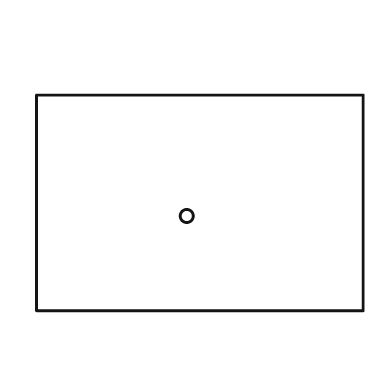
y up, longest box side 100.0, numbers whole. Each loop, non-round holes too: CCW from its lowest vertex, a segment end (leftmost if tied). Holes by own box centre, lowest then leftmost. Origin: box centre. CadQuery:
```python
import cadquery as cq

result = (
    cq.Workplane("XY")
    .moveTo(-50.0, -33.0)
    .lineTo(50.0, -33.0)
    .lineTo(50.0, 33.0)
    .lineTo(-50.0, 33.0)
    .close()
    .moveTo(-4.0, -4.0)
    .circle(2.0)
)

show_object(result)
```